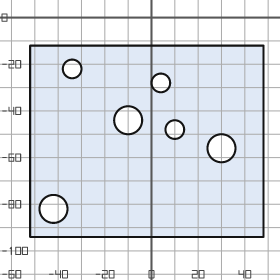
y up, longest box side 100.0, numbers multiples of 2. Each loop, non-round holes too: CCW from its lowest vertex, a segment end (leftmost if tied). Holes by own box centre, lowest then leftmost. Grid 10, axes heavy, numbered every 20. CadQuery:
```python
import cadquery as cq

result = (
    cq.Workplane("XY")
    .moveTo(-52.0, -94.0)
    .lineTo(48.0, -94.0)
    .lineTo(48.0, -12.0)
    .lineTo(-52.0, -12.0)
    .close()
    .moveTo(-42.0, -82.0)
    .circle(6.0)
    .moveTo(30.0, -56.0)
    .circle(6.0)
    .moveTo(10.0, -48.0)
    .circle(4.0)
    .moveTo(-10.0, -44.0)
    .circle(6.0)
    .moveTo(4.0, -28.0)
    .circle(4.0)
    .moveTo(-34.0, -22.0)
    .circle(4.0)
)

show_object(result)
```